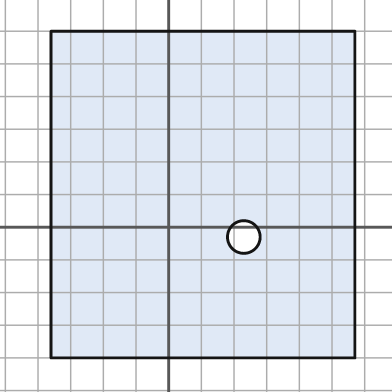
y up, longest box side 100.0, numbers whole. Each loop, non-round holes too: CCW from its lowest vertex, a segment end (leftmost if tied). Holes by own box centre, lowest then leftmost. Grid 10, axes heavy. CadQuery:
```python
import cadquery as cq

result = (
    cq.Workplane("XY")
    .moveTo(-36.0, -40.0)
    .lineTo(57.0, -40.0)
    .lineTo(57.0, 60.0)
    .lineTo(-36.0, 60.0)
    .close()
    .moveTo(23.0, -3.0)
    .circle(5.0)
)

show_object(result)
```